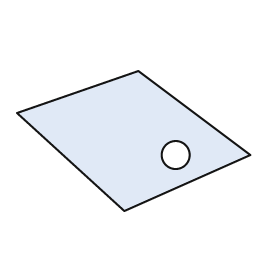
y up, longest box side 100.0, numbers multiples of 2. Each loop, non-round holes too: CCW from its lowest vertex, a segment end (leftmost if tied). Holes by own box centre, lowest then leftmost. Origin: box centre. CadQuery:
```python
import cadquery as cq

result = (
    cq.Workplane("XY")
    .moveTo(-4.0, -30.0)
    .lineTo(50.0, -6.0)
    .lineTo(2.0, 30.0)
    .lineTo(-50.0, 12.0)
    .close()
    .moveTo(18.0, -6.0)
    .circle(6.0)
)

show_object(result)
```